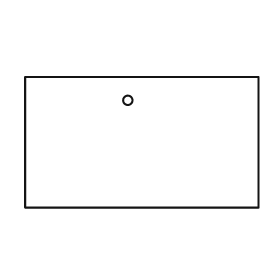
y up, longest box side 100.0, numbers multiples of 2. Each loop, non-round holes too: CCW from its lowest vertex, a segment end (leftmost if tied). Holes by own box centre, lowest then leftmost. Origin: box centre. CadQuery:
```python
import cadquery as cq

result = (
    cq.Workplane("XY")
    .moveTo(-50.0, -28.0)
    .lineTo(50.0, -28.0)
    .lineTo(50.0, 28.0)
    .lineTo(-50.0, 28.0)
    .close()
    .moveTo(-6.0, 18.0)
    .circle(2.0)
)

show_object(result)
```